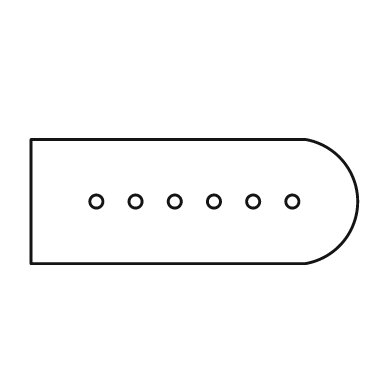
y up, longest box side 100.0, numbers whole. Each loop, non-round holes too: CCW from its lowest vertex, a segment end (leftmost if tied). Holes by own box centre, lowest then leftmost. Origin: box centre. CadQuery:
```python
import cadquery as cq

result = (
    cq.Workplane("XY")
    .moveTo(-50.0, -19.0)
    .lineTo(34.0, -19.0)
    .threePointArc((50.0, 0.0), (34.0, 19.0))
    .lineTo(-50.0, 19.0)
    .close()
    .moveTo(-30.0, 0.0)
    .circle(2.0)
    .moveTo(-18.0, 0.0)
    .circle(2.0)
    .moveTo(-6.0, 0.0)
    .circle(2.0)
    .moveTo(6.0, 0.0)
    .circle(2.0)
    .moveTo(18.0, 0.0)
    .circle(2.0)
    .moveTo(30.0, 0.0)
    .circle(2.0)
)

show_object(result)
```